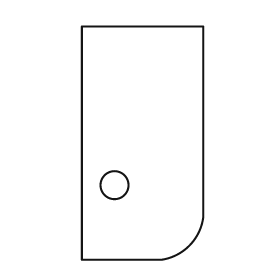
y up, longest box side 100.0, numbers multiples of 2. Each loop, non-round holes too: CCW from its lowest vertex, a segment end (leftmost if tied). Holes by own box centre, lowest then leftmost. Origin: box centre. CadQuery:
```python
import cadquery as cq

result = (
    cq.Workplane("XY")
    .moveTo(-26.0, -50.0)
    .lineTo(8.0, -50.0)
    .threePointArc((20.0, -44.0), (26.0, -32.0))
    .lineTo(26.0, 50.0)
    .lineTo(-26.0, 50.0)
    .close()
    .moveTo(-12.0, -18.0)
    .circle(6.0)
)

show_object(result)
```